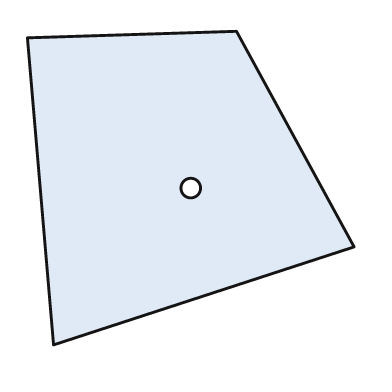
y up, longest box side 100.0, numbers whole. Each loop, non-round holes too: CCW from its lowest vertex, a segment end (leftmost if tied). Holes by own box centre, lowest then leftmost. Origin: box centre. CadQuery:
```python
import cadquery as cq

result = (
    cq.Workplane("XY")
    .moveTo(-42.0, -48.0)
    .lineTo(50.0, -18.0)
    .lineTo(14.0, 48.0)
    .lineTo(-50.0, 46.0)
    .close()
    .moveTo(0.0, 0.0)
    .circle(3.0)
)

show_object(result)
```